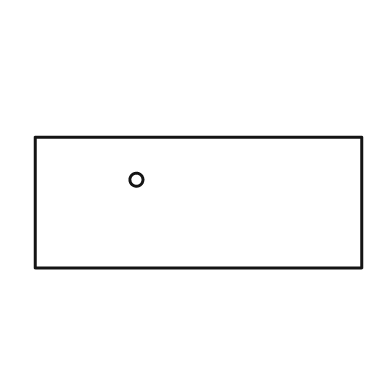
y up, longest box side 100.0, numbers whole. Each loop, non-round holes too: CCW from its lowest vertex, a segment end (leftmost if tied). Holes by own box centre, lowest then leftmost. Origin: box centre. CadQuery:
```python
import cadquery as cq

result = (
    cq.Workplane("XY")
    .moveTo(-50.0, -20.0)
    .lineTo(50.0, -20.0)
    .lineTo(50.0, 20.0)
    .lineTo(-50.0, 20.0)
    .close()
    .moveTo(-19.0, 7.0)
    .circle(2.0)
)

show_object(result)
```